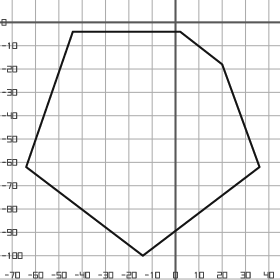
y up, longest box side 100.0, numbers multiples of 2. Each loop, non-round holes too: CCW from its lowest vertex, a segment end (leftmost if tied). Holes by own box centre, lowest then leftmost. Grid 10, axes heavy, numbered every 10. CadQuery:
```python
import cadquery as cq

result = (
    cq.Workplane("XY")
    .moveTo(-14.0, -100.0)
    .lineTo(36.0, -62.0)
    .lineTo(20.0, -18.0)
    .lineTo(2.0, -4.0)
    .lineTo(-44.0, -4.0)
    .lineTo(-64.0, -62.0)
    .close()
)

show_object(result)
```